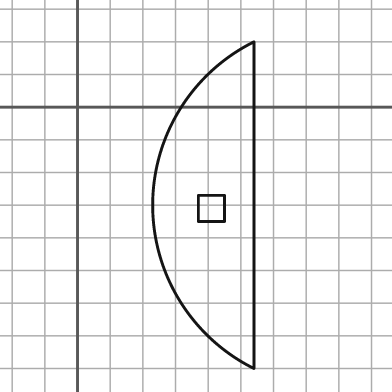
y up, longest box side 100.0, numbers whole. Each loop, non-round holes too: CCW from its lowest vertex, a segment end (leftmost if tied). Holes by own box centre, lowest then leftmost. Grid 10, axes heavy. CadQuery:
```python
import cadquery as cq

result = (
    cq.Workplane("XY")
    .moveTo(54.0, -80.0)
    .lineTo(54.0, 20.0)
    .threePointArc((23.0, -30.0), (54.0, -80.0))
    .close()
    .moveTo(37.0, -35.0)
    .lineTo(45.0, -35.0)
    .lineTo(45.0, -27.0)
    .lineTo(37.0, -27.0)
    .close()
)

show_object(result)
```